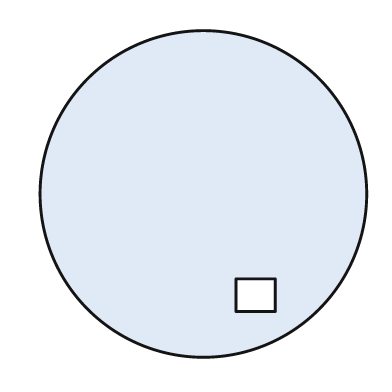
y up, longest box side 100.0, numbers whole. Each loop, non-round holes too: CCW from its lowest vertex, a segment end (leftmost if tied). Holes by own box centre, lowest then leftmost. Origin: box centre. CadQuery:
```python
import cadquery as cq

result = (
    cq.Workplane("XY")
    .moveTo(0.0, 0.0)
    .circle(50.0)
    .moveTo(10.0, -36.0)
    .lineTo(22.0, -36.0)
    .lineTo(22.0, -26.0)
    .lineTo(10.0, -26.0)
    .close()
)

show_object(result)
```